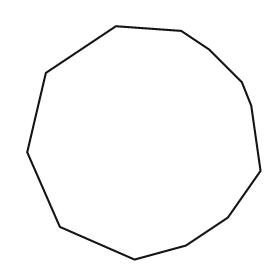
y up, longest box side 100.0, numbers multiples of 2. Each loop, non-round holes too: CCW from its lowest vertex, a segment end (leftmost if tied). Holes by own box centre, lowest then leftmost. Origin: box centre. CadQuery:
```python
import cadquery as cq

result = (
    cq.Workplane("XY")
    .moveTo(-4.0, -50.0)
    .lineTo(18.0, -44.0)
    .lineTo(36.0, -32.0)
    .lineTo(50.0, -12.0)
    .lineTo(46.0, 16.0)
    .lineTo(42.0, 26.0)
    .lineTo(28.0, 40.0)
    .lineTo(16.0, 48.0)
    .lineTo(-12.0, 50.0)
    .lineTo(-42.0, 30.0)
    .lineTo(-50.0, -4.0)
    .lineTo(-36.0, -36.0)
    .close()
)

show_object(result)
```